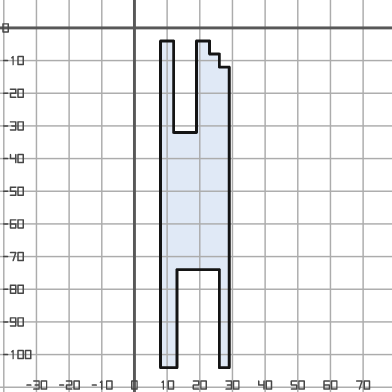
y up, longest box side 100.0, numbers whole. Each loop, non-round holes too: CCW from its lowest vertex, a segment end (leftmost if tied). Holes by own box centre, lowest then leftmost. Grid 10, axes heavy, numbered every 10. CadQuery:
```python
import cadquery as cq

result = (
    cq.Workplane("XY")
    .moveTo(8.0, -104.0)
    .lineTo(13.0, -104.0)
    .lineTo(13.0, -74.0)
    .lineTo(26.0, -74.0)
    .lineTo(26.0, -104.0)
    .lineTo(29.0, -104.0)
    .lineTo(29.0, -12.0)
    .lineTo(26.0, -12.0)
    .lineTo(26.0, -8.0)
    .lineTo(23.0, -8.0)
    .lineTo(23.0, -4.0)
    .lineTo(19.0, -4.0)
    .lineTo(19.0, -32.0)
    .lineTo(12.0, -32.0)
    .lineTo(12.0, -4.0)
    .lineTo(8.0, -4.0)
    .close()
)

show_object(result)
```